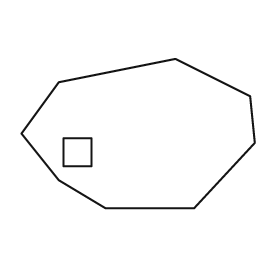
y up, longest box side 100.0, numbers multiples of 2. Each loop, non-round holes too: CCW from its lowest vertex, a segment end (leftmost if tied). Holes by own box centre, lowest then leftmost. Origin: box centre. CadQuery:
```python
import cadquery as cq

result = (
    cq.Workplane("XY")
    .moveTo(-14.0, -32.0)
    .lineTo(24.0, -32.0)
    .lineTo(50.0, -4.0)
    .lineTo(48.0, 16.0)
    .lineTo(16.0, 32.0)
    .lineTo(-34.0, 22.0)
    .lineTo(-50.0, 0.0)
    .lineTo(-34.0, -20.0)
    .close()
    .moveTo(-32.0, -14.0)
    .lineTo(-20.0, -14.0)
    .lineTo(-20.0, -2.0)
    .lineTo(-32.0, -2.0)
    .close()
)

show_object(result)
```